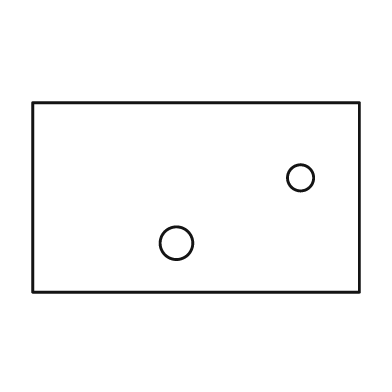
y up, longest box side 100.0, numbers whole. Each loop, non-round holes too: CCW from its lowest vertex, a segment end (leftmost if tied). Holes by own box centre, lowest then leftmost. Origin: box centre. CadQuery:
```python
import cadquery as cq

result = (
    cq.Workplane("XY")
    .moveTo(-50.0, -29.0)
    .lineTo(50.0, -29.0)
    .lineTo(50.0, 29.0)
    .lineTo(-50.0, 29.0)
    .close()
    .moveTo(-6.0, -14.0)
    .circle(5.0)
    .moveTo(32.0, 6.0)
    .circle(4.0)
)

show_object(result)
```